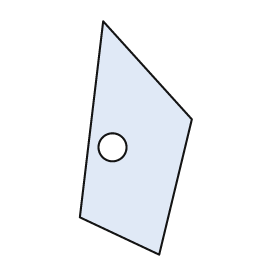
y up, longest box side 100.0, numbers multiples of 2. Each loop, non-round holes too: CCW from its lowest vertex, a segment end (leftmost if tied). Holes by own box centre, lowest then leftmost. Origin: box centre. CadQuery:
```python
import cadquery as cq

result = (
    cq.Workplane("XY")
    .moveTo(10.0, -50.0)
    .lineTo(24.0, 8.0)
    .lineTo(-14.0, 50.0)
    .lineTo(-24.0, -34.0)
    .close()
    .moveTo(-10.0, -4.0)
    .circle(6.0)
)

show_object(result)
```